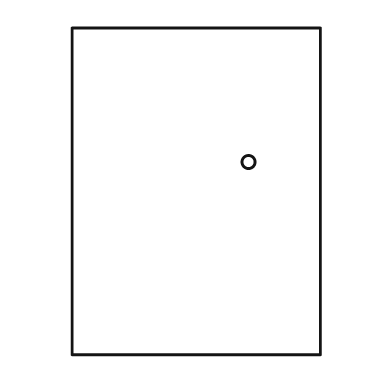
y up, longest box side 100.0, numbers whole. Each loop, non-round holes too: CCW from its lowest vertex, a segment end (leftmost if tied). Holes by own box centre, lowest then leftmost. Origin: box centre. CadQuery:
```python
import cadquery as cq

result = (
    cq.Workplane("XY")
    .moveTo(-38.0, -50.0)
    .lineTo(38.0, -50.0)
    .lineTo(38.0, 50.0)
    .lineTo(-38.0, 50.0)
    .close()
    .moveTo(16.0, 9.0)
    .circle(2.0)
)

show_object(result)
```